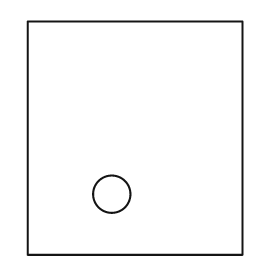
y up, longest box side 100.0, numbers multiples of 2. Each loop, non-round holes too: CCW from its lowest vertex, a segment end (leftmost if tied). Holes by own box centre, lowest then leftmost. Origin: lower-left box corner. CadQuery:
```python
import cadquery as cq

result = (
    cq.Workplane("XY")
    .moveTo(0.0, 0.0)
    .lineTo(92.0, 0.0)
    .lineTo(92.0, 100.0)
    .lineTo(0.0, 100.0)
    .close()
    .moveTo(36.0, 26.0)
    .circle(8.0)
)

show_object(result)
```